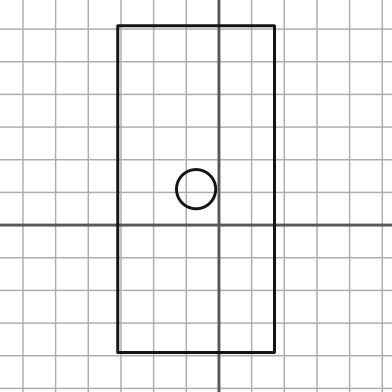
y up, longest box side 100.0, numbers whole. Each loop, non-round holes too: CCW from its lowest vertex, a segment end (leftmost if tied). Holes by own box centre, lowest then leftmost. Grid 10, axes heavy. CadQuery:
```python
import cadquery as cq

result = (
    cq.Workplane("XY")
    .moveTo(-31.0, -39.0)
    .lineTo(17.0, -39.0)
    .lineTo(17.0, 61.0)
    .lineTo(-31.0, 61.0)
    .close()
    .moveTo(-7.0, 11.0)
    .circle(6.0)
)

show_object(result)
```